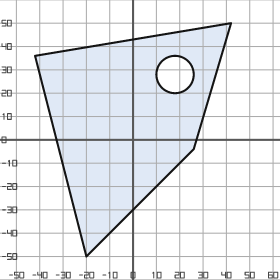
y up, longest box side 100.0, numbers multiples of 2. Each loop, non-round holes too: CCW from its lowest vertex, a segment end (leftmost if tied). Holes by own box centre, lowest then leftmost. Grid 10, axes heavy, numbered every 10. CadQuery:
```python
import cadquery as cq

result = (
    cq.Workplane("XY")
    .moveTo(-20.0, -50.0)
    .lineTo(26.0, -4.0)
    .lineTo(42.0, 50.0)
    .lineTo(-42.0, 36.0)
    .close()
    .moveTo(18.0, 28.0)
    .circle(8.0)
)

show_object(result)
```